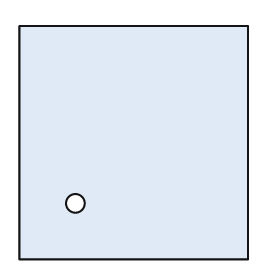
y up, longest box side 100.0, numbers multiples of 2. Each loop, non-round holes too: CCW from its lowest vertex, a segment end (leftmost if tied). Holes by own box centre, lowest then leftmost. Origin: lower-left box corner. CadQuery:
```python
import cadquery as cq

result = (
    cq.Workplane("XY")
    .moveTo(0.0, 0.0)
    .lineTo(98.0, 0.0)
    .lineTo(98.0, 100.0)
    .lineTo(0.0, 100.0)
    .close()
    .moveTo(24.0, 24.0)
    .circle(4.0)
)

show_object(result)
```